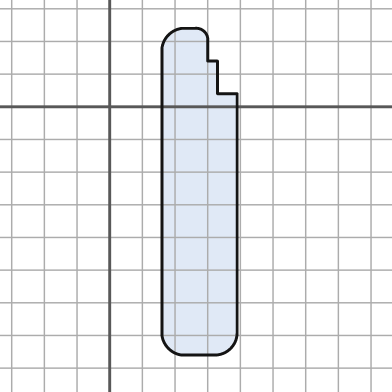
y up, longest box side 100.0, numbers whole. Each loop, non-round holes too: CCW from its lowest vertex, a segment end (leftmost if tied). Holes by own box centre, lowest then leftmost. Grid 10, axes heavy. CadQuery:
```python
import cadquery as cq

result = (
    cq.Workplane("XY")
    .moveTo(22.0, -76.0)
    .lineTo(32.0, -76.0)
    .threePointArc((37.0, -74.0), (39.0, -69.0))
    .lineTo(39.0, 4.0)
    .lineTo(33.0, 4.0)
    .lineTo(33.0, 14.0)
    .lineTo(30.0, 14.0)
    .lineTo(30.0, 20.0)
    .threePointArc((29.0, 23.0), (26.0, 24.0))
    .lineTo(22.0, 24.0)
    .threePointArc((18.0, 22.0), (16.0, 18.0))
    .lineTo(16.0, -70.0)
    .threePointArc((18.0, -74.0), (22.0, -76.0))
    .close()
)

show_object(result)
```